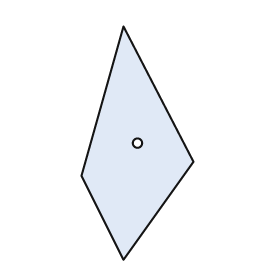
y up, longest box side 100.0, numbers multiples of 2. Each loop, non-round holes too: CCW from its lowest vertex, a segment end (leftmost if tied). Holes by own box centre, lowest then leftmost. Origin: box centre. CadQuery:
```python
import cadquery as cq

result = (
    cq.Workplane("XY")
    .moveTo(-6.0, -50.0)
    .lineTo(24.0, -8.0)
    .lineTo(-6.0, 50.0)
    .lineTo(-24.0, -14.0)
    .close()
    .moveTo(0.0, 0.0)
    .circle(2.0)
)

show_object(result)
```